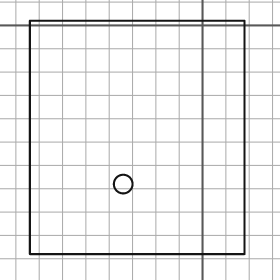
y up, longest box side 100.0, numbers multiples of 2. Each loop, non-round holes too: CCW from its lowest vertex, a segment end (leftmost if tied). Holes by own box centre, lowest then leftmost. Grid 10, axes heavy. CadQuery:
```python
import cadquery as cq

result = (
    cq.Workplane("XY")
    .moveTo(-74.0, -98.0)
    .lineTo(18.0, -98.0)
    .lineTo(18.0, 2.0)
    .lineTo(-74.0, 2.0)
    .close()
    .moveTo(-34.0, -68.0)
    .circle(4.0)
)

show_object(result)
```